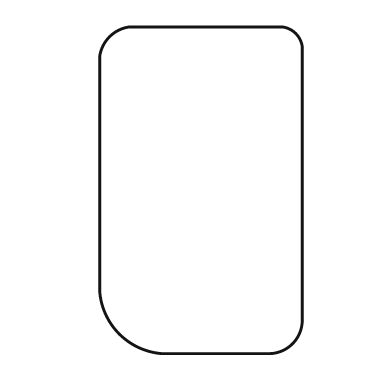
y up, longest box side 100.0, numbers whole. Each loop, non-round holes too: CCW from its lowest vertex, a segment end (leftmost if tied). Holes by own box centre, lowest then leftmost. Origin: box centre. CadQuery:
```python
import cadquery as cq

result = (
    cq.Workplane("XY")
    .moveTo(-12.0, -50.0)
    .lineTo(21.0, -50.0)
    .threePointArc((28.0, -47.0), (31.0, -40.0))
    .lineTo(31.0, 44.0)
    .threePointArc((29.0, 48.0), (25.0, 50.0))
    .lineTo(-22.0, 50.0)
    .threePointArc((-28.0, 47.0), (-31.0, 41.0))
    .lineTo(-31.0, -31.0)
    .threePointArc((-25.0, -44.0), (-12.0, -50.0))
    .close()
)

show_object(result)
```